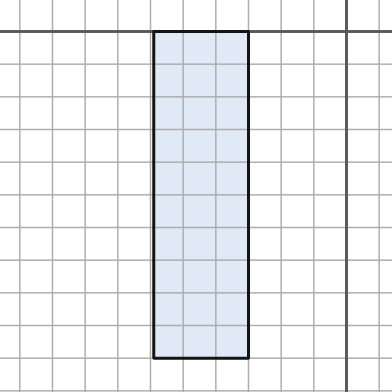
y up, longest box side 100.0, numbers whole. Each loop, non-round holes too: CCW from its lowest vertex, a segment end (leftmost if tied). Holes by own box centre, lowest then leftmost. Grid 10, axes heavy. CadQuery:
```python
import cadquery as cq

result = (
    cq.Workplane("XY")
    .moveTo(-59.0, -100.0)
    .lineTo(-30.0, -100.0)
    .lineTo(-30.0, 0.0)
    .lineTo(-59.0, 0.0)
    .close()
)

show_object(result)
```